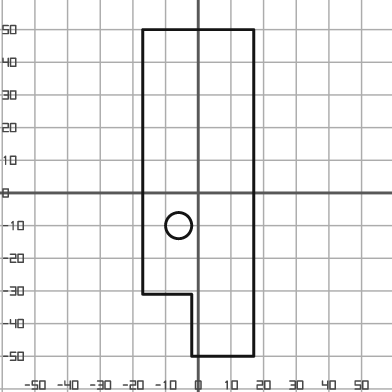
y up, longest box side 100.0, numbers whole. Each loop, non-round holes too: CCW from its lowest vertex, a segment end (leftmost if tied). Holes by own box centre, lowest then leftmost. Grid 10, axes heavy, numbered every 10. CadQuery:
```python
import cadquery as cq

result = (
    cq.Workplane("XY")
    .moveTo(-2.0, -50.0)
    .lineTo(17.0, -50.0)
    .lineTo(17.0, 50.0)
    .lineTo(-17.0, 50.0)
    .lineTo(-17.0, -31.0)
    .lineTo(-2.0, -31.0)
    .close()
    .moveTo(-6.0, -10.0)
    .circle(4.0)
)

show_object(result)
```